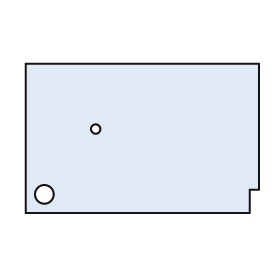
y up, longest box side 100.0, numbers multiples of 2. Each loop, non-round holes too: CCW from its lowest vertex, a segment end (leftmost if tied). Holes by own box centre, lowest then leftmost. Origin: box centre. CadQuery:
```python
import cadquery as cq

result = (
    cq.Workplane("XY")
    .moveTo(-50.0, -32.0)
    .lineTo(46.0, -32.0)
    .lineTo(46.0, -22.0)
    .lineTo(50.0, -22.0)
    .lineTo(50.0, 32.0)
    .lineTo(-50.0, 32.0)
    .close()
    .moveTo(-42.0, -24.0)
    .circle(4.0)
    .moveTo(-20.0, 4.0)
    .circle(2.0)
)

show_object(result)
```